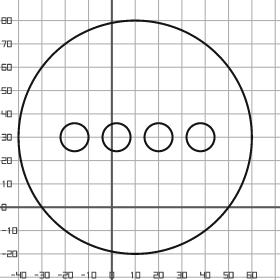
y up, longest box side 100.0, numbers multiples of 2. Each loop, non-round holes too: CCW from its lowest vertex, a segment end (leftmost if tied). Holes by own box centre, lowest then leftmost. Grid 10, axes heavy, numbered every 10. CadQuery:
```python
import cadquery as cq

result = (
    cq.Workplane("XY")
    .moveTo(10.0, 30.0)
    .circle(50.0)
    .moveTo(-16.0, 30.0)
    .circle(6.0)
    .moveTo(2.0, 30.0)
    .circle(6.0)
    .moveTo(20.0, 30.0)
    .circle(6.0)
    .moveTo(38.0, 30.0)
    .circle(6.0)
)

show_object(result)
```